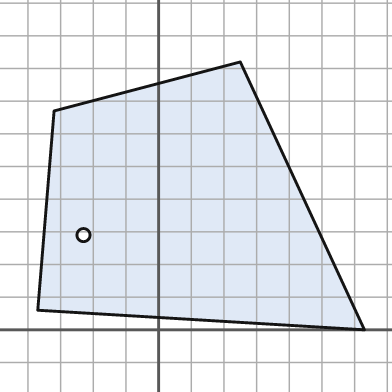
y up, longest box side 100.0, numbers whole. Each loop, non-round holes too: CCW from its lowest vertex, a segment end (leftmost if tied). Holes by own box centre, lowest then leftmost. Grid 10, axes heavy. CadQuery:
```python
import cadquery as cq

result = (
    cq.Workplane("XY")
    .moveTo(63.0, 0.0)
    .lineTo(25.0, 82.0)
    .lineTo(-32.0, 67.0)
    .lineTo(-37.0, 6.0)
    .close()
    .moveTo(-23.0, 29.0)
    .circle(2.0)
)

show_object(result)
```